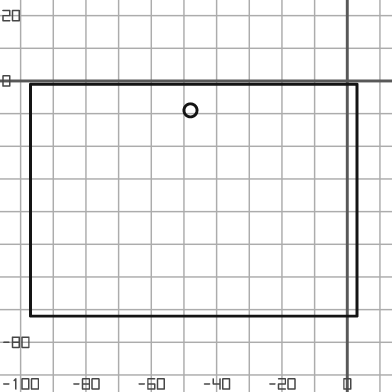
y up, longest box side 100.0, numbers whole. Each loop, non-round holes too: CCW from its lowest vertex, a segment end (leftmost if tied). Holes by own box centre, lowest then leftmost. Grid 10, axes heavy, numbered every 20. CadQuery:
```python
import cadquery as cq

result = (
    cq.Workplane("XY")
    .moveTo(-97.0, -72.0)
    .lineTo(3.0, -72.0)
    .lineTo(3.0, -1.0)
    .lineTo(-97.0, -1.0)
    .close()
    .moveTo(-48.0, -9.0)
    .circle(2.0)
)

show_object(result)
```